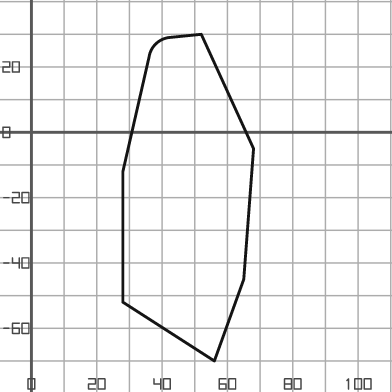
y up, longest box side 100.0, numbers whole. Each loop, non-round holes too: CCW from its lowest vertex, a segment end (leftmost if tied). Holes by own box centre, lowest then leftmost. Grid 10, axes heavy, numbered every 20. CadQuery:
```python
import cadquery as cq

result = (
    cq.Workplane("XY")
    .moveTo(56.0, -70.0)
    .lineTo(65.0, -45.0)
    .lineTo(68.0, -5.0)
    .lineTo(52.0, 30.0)
    .lineTo(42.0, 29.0)
    .threePointArc((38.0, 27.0), (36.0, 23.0))
    .lineTo(28.0, -12.0)
    .lineTo(28.0, -52.0)
    .close()
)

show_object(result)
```